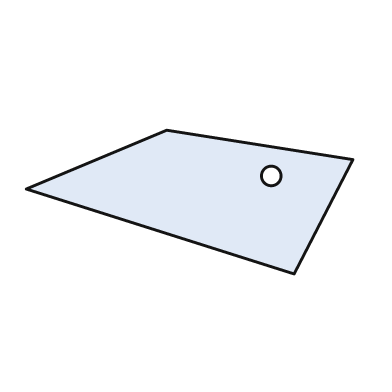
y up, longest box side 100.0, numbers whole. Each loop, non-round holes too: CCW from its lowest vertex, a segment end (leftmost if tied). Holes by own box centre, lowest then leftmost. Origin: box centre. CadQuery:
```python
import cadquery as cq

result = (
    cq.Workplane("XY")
    .moveTo(32.0, -22.0)
    .lineTo(50.0, 13.0)
    .lineTo(-7.0, 22.0)
    .lineTo(-50.0, 4.0)
    .close()
    .moveTo(25.0, 8.0)
    .circle(3.0)
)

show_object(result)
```